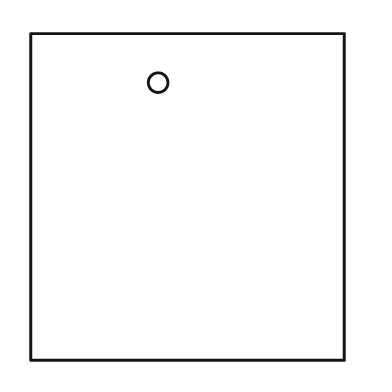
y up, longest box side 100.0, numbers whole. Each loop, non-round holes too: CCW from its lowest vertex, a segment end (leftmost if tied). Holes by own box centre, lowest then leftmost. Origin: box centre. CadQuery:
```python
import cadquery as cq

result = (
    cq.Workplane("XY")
    .moveTo(-48.0, -50.0)
    .lineTo(48.0, -50.0)
    .lineTo(48.0, 50.0)
    .lineTo(-48.0, 50.0)
    .close()
    .moveTo(-9.0, 35.0)
    .circle(3.0)
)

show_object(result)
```